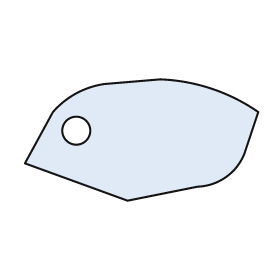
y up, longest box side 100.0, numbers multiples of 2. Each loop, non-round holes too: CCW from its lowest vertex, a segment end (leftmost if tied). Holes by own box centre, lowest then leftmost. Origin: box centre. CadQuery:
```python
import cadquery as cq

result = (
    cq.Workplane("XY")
    .moveTo(-6.0, -26.0)
    .lineTo(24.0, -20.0)
    .threePointArc((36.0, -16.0), (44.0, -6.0))
    .lineTo(50.0, 12.0)
    .threePointArc((30.0, 22.0), (8.0, 26.0))
    .lineTo(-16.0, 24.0)
    .threePointArc((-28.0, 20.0), (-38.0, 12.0))
    .lineTo(-50.0, -10.0)
    .close()
    .moveTo(-28.0, 4.0)
    .circle(6.0)
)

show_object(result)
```